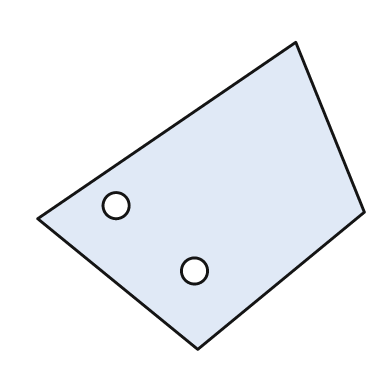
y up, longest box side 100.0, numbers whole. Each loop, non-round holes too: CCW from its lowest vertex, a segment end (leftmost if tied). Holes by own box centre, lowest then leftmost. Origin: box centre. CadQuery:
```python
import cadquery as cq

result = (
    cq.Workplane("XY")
    .moveTo(-1.0, -47.0)
    .lineTo(50.0, -5.0)
    .lineTo(29.0, 47.0)
    .lineTo(-50.0, -7.0)
    .close()
    .moveTo(-2.0, -23.0)
    .circle(4.0)
    .moveTo(-26.0, -3.0)
    .circle(4.0)
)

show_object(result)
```